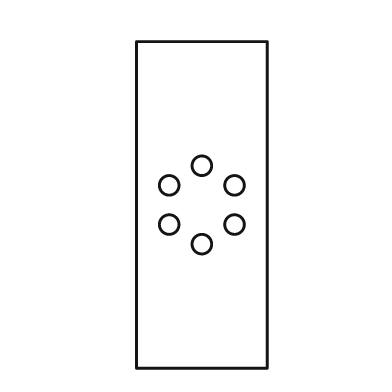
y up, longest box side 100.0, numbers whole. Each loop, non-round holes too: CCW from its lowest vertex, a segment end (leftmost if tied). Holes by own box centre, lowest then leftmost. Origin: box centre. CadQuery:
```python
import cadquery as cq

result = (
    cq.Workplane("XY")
    .moveTo(-20.0, -50.0)
    .lineTo(20.0, -50.0)
    .lineTo(20.0, 50.0)
    .lineTo(-20.0, 50.0)
    .close()
    .moveTo(0.0, -12.0)
    .circle(3.0)
    .moveTo(-10.0, -6.0)
    .circle(3.0)
    .moveTo(10.0, -6.0)
    .circle(3.0)
    .moveTo(-10.0, 6.0)
    .circle(3.0)
    .moveTo(10.0, 6.0)
    .circle(3.0)
    .moveTo(0.0, 12.0)
    .circle(3.0)
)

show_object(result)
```